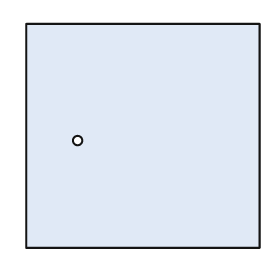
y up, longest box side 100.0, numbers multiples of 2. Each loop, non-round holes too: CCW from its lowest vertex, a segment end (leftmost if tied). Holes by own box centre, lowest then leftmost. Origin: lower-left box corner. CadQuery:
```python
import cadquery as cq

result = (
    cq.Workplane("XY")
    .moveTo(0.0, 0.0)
    .lineTo(100.0, 0.0)
    .lineTo(100.0, 96.0)
    .lineTo(0.0, 96.0)
    .close()
    .moveTo(22.0, 46.0)
    .circle(2.0)
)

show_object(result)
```